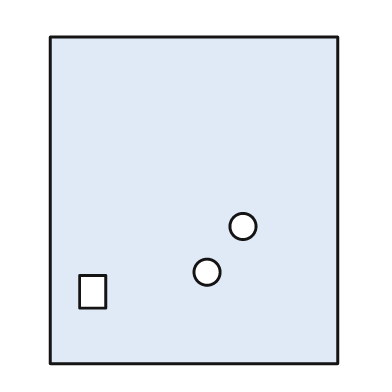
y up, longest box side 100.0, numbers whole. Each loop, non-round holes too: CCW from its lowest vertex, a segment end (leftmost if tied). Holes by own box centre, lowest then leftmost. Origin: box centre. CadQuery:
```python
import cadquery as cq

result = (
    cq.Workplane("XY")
    .moveTo(-44.0, -50.0)
    .lineTo(44.0, -50.0)
    .lineTo(44.0, 50.0)
    .lineTo(-44.0, 50.0)
    .close()
    .moveTo(-35.0, -33.0)
    .lineTo(-27.0, -33.0)
    .lineTo(-27.0, -23.0)
    .lineTo(-35.0, -23.0)
    .close()
    .moveTo(4.0, -22.0)
    .circle(4.0)
    .moveTo(15.0, -8.0)
    .circle(4.0)
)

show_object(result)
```